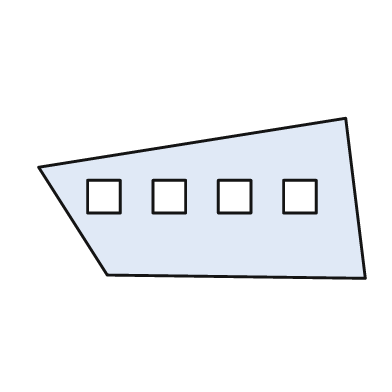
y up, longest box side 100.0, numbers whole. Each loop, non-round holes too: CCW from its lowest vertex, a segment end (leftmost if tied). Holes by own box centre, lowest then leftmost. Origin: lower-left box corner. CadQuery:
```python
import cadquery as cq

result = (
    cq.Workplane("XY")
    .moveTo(100.0, 0.0)
    .lineTo(94.0, 49.0)
    .lineTo(0.0, 34.0)
    .lineTo(21.0, 1.0)
    .close()
    .moveTo(15.0, 20.0)
    .lineTo(25.0, 20.0)
    .lineTo(25.0, 30.0)
    .lineTo(15.0, 30.0)
    .close()
    .moveTo(35.0, 20.0)
    .lineTo(45.0, 20.0)
    .lineTo(45.0, 30.0)
    .lineTo(35.0, 30.0)
    .close()
    .moveTo(55.0, 20.0)
    .lineTo(65.0, 20.0)
    .lineTo(65.0, 30.0)
    .lineTo(55.0, 30.0)
    .close()
    .moveTo(75.0, 20.0)
    .lineTo(85.0, 20.0)
    .lineTo(85.0, 30.0)
    .lineTo(75.0, 30.0)
    .close()
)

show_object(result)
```